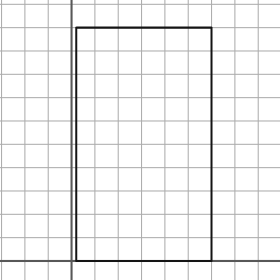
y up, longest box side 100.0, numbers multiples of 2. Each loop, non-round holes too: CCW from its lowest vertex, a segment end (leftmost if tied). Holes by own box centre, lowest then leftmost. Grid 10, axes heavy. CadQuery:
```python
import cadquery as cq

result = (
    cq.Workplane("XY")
    .moveTo(2.0, 0.0)
    .lineTo(60.0, 0.0)
    .lineTo(60.0, 100.0)
    .lineTo(2.0, 100.0)
    .close()
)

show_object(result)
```